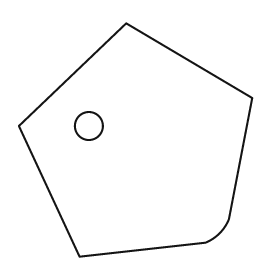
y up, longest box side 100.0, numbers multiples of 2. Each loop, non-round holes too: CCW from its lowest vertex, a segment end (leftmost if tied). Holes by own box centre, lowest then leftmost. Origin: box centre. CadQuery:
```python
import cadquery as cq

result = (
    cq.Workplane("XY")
    .moveTo(-24.0, -50.0)
    .lineTo(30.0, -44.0)
    .threePointArc((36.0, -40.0), (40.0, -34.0))
    .lineTo(50.0, 18.0)
    .lineTo(-4.0, 50.0)
    .lineTo(-50.0, 6.0)
    .close()
    .moveTo(-20.0, 6.0)
    .circle(6.0)
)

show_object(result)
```